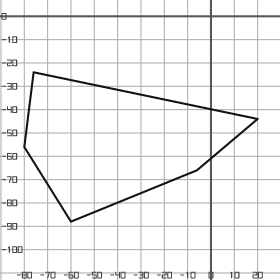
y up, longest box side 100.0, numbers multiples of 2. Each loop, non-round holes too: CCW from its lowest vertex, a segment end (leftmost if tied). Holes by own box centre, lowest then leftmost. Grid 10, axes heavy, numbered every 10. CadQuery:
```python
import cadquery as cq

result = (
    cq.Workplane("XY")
    .moveTo(-60.0, -88.0)
    .lineTo(-6.0, -66.0)
    .lineTo(20.0, -44.0)
    .lineTo(-76.0, -24.0)
    .lineTo(-80.0, -56.0)
    .close()
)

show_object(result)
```